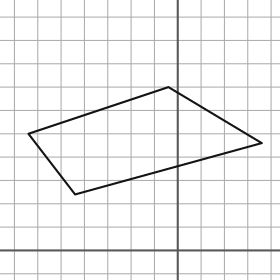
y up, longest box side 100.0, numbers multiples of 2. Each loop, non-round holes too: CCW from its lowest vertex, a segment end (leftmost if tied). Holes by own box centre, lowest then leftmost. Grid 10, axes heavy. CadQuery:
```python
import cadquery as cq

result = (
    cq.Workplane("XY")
    .moveTo(-44.0, 24.0)
    .lineTo(36.0, 46.0)
    .lineTo(-4.0, 70.0)
    .lineTo(-64.0, 50.0)
    .close()
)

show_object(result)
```